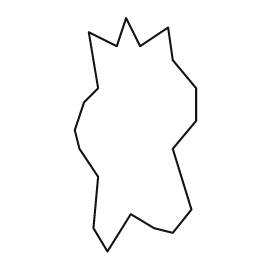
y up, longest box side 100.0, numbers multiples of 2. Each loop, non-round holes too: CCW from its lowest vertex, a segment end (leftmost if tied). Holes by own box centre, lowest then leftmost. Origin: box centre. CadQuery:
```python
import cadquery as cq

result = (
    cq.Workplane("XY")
    .moveTo(-12.0, -50.0)
    .lineTo(-2.0, -34.0)
    .lineTo(8.0, -40.0)
    .lineTo(16.0, -42.0)
    .lineTo(24.0, -32.0)
    .lineTo(16.0, -6.0)
    .lineTo(26.0, 6.0)
    .lineTo(26.0, 20.0)
    .lineTo(16.0, 32.0)
    .lineTo(14.0, 46.0)
    .lineTo(2.0, 38.0)
    .lineTo(-4.0, 50.0)
    .lineTo(-8.0, 38.0)
    .lineTo(-20.0, 44.0)
    .lineTo(-16.0, 20.0)
    .lineTo(-22.0, 14.0)
    .lineTo(-26.0, 2.0)
    .lineTo(-24.0, -6.0)
    .lineTo(-16.0, -18.0)
    .lineTo(-18.0, -40.0)
    .close()
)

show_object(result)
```